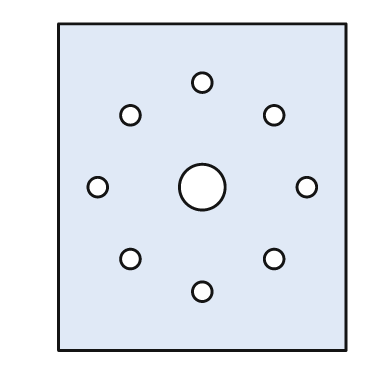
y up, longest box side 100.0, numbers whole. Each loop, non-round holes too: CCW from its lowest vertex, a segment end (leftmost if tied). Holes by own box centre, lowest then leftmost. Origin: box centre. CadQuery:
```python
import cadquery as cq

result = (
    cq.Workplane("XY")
    .moveTo(-44.0, -50.0)
    .lineTo(44.0, -50.0)
    .lineTo(44.0, 50.0)
    .lineTo(-44.0, 50.0)
    .close()
    .moveTo(0.0, -32.0)
    .circle(3.0)
    .moveTo(-22.0, -22.0)
    .circle(3.0)
    .moveTo(22.0, -22.0)
    .circle(3.0)
    .moveTo(-32.0, 0.0)
    .circle(3.0)
    .moveTo(0.0, 0.0)
    .circle(7.0)
    .moveTo(32.0, 0.0)
    .circle(3.0)
    .moveTo(-22.0, 22.0)
    .circle(3.0)
    .moveTo(22.0, 22.0)
    .circle(3.0)
    .moveTo(0.0, 32.0)
    .circle(3.0)
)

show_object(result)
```